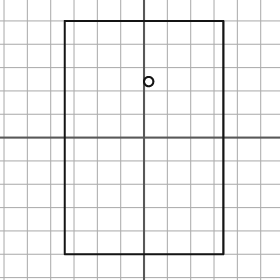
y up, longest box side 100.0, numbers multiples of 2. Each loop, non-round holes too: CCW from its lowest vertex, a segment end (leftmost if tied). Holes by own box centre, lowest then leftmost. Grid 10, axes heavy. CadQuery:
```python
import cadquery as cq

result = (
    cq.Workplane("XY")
    .moveTo(-34.0, -50.0)
    .lineTo(34.0, -50.0)
    .lineTo(34.0, 50.0)
    .lineTo(-34.0, 50.0)
    .close()
    .moveTo(2.0, 24.0)
    .circle(2.0)
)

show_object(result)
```